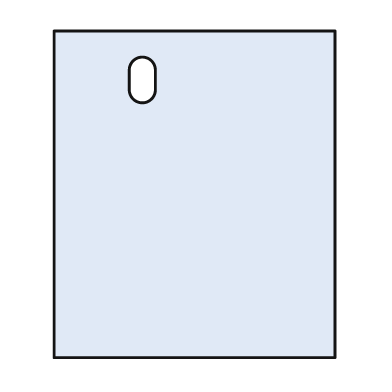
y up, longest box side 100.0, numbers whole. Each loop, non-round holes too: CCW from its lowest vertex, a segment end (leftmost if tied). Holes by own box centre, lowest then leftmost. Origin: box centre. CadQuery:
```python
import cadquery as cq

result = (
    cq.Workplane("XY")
    .moveTo(-43.0, -50.0)
    .lineTo(43.0, -50.0)
    .lineTo(43.0, 50.0)
    .lineTo(-43.0, 50.0)
    .close()
    .moveTo(-20.0, 32.0)
    .threePointArc((-16.0, 28.0), (-12.0, 32.0))
    .lineTo(-12.0, 38.0)
    .threePointArc((-16.0, 42.0), (-20.0, 38.0))
    .close()
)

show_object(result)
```